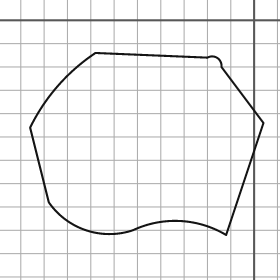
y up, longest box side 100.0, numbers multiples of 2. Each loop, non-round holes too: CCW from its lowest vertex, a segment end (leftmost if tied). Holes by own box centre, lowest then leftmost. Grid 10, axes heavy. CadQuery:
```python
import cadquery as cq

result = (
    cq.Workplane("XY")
    .moveTo(-12.0, -92.0)
    .lineTo(4.0, -44.0)
    .lineTo(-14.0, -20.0)
    .threePointArc((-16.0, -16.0), (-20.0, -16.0))
    .lineTo(-68.0, -14.0)
    .threePointArc((-84.0, -28.0), (-96.0, -46.0))
    .lineTo(-88.0, -78.0)
    .threePointArc((-72.0, -90.0), (-52.0, -90.0))
    .threePointArc((-32.0, -86.0), (-12.0, -92.0))
    .close()
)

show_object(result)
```